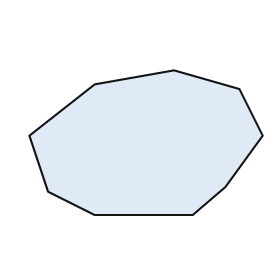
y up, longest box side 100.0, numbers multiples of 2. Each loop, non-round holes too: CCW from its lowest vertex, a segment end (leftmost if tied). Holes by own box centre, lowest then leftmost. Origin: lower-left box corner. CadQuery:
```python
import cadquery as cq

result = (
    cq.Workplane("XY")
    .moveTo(28.0, 0.0)
    .lineTo(70.0, 0.0)
    .lineTo(84.0, 12.0)
    .lineTo(100.0, 34.0)
    .lineTo(90.0, 54.0)
    .lineTo(62.0, 62.0)
    .lineTo(28.0, 56.0)
    .lineTo(0.0, 34.0)
    .lineTo(8.0, 10.0)
    .close()
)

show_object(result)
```